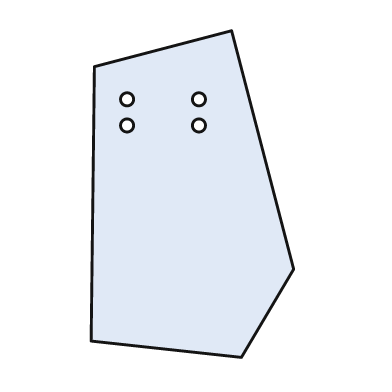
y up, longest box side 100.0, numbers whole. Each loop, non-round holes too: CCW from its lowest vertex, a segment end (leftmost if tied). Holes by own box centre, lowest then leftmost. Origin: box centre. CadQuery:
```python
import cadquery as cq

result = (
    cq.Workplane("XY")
    .moveTo(15.0, -50.0)
    .lineTo(31.0, -23.0)
    .lineTo(12.0, 50.0)
    .lineTo(-30.0, 39.0)
    .lineTo(-31.0, -45.0)
    .close()
    .moveTo(-20.0, 21.0)
    .circle(2.0)
    .moveTo(2.0, 21.0)
    .circle(2.0)
    .moveTo(-20.0, 29.0)
    .circle(2.0)
    .moveTo(2.0, 29.0)
    .circle(2.0)
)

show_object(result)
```